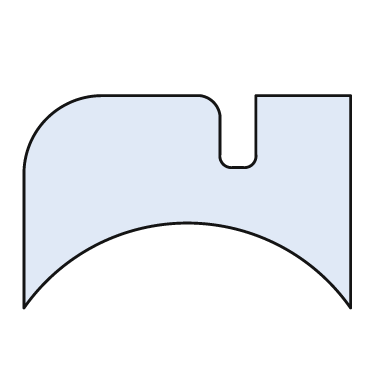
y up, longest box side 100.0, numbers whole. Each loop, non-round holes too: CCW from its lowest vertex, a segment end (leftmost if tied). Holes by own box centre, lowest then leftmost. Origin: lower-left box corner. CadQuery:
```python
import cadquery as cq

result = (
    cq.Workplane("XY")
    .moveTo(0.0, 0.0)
    .threePointArc((50.0, 26.0), (100.0, 0.0))
    .lineTo(100.0, 65.0)
    .lineTo(71.0, 65.0)
    .lineTo(71.0, 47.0)
    .threePointArc((70.0, 44.0), (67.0, 43.0))
    .lineTo(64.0, 43.0)
    .threePointArc((61.0, 44.0), (60.0, 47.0))
    .lineTo(60.0, 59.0)
    .threePointArc((58.0, 63.0), (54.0, 65.0))
    .lineTo(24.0, 65.0)
    .threePointArc((7.0, 58.0), (0.0, 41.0))
    .close()
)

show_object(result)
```